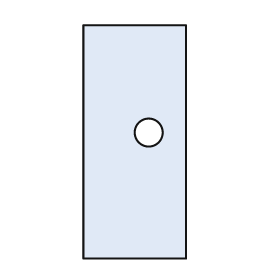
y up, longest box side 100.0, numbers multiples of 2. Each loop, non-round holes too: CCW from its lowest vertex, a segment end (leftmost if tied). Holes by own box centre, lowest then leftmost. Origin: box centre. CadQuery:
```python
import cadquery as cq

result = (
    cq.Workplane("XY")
    .moveTo(-22.0, -50.0)
    .lineTo(22.0, -50.0)
    .lineTo(22.0, 50.0)
    .lineTo(-22.0, 50.0)
    .close()
    .moveTo(6.0, 4.0)
    .circle(6.0)
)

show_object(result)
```